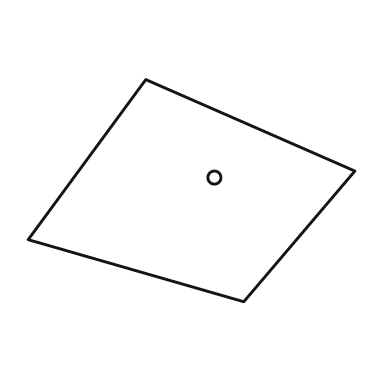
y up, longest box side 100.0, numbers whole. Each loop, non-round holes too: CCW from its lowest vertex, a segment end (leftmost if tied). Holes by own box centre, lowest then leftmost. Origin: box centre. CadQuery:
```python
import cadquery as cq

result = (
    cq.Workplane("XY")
    .moveTo(16.0, -34.0)
    .lineTo(50.0, 6.0)
    .lineTo(-14.0, 34.0)
    .lineTo(-50.0, -15.0)
    .close()
    .moveTo(7.0, 4.0)
    .circle(2.0)
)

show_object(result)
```